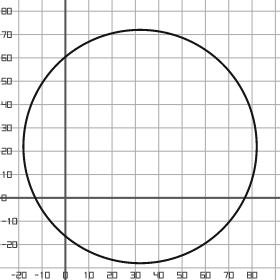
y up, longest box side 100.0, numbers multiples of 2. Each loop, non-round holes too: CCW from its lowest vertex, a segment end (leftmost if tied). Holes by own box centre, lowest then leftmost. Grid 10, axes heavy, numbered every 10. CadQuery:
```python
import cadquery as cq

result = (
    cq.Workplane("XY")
    .moveTo(32.0, 22.0)
    .circle(50.0)
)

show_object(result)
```